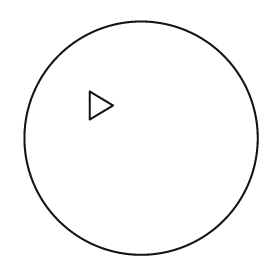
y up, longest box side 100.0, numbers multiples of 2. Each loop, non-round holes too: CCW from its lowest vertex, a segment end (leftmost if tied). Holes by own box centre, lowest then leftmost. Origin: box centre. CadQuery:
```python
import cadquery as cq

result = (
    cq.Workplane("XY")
    .moveTo(0.0, 0.0)
    .circle(50.0)
    .moveTo(-22.0, 8.0)
    .lineTo(-12.0, 14.0)
    .lineTo(-22.0, 20.0)
    .close()
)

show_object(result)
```